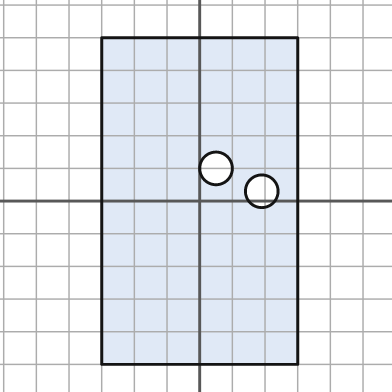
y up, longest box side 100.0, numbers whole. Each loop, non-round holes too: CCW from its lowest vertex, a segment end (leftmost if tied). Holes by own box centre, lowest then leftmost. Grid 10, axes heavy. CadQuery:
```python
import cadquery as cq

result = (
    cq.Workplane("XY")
    .moveTo(-30.0, -50.0)
    .lineTo(30.0, -50.0)
    .lineTo(30.0, 50.0)
    .lineTo(-30.0, 50.0)
    .close()
    .moveTo(19.0, 3.0)
    .circle(5.0)
    .moveTo(5.0, 10.0)
    .circle(5.0)
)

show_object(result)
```